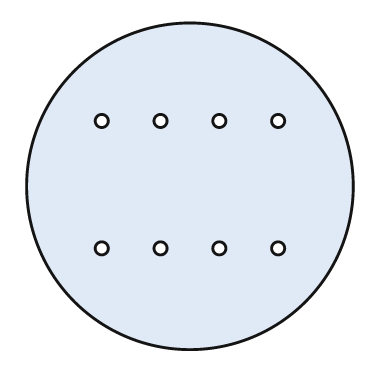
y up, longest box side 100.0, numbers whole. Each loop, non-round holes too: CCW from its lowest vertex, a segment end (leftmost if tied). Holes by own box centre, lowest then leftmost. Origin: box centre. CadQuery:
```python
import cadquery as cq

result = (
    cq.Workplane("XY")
    .moveTo(0.0, 0.0)
    .circle(50.0)
    .moveTo(-27.0, -19.0)
    .circle(2.0)
    .moveTo(-9.0, -19.0)
    .circle(2.0)
    .moveTo(9.0, -19.0)
    .circle(2.0)
    .moveTo(27.0, -19.0)
    .circle(2.0)
    .moveTo(-27.0, 20.0)
    .circle(2.0)
    .moveTo(-9.0, 20.0)
    .circle(2.0)
    .moveTo(9.0, 20.0)
    .circle(2.0)
    .moveTo(27.0, 20.0)
    .circle(2.0)
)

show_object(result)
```